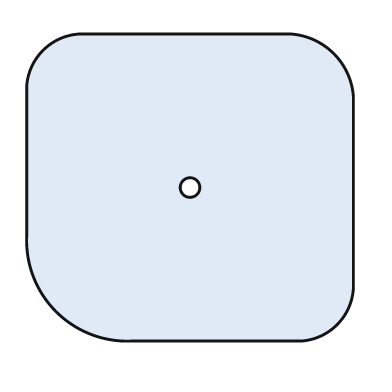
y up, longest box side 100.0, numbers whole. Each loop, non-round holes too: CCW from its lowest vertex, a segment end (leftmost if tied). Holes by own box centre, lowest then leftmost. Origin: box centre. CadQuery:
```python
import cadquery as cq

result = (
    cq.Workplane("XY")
    .moveTo(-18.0, -47.0)
    .lineTo(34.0, -47.0)
    .threePointArc((45.0, -42.0), (50.0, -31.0))
    .lineTo(50.0, 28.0)
    .threePointArc((44.0, 41.0), (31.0, 47.0))
    .lineTo(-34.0, 47.0)
    .threePointArc((-45.0, 42.0), (-50.0, 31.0))
    .lineTo(-50.0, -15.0)
    .threePointArc((-41.0, -38.0), (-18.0, -47.0))
    .close()
    .moveTo(0.0, 0.0)
    .circle(3.0)
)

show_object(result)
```